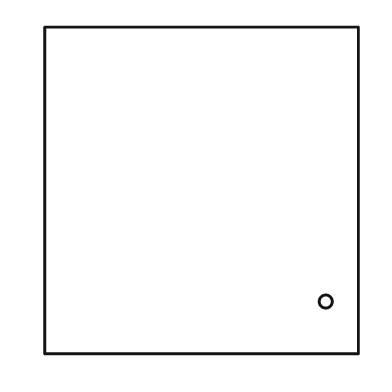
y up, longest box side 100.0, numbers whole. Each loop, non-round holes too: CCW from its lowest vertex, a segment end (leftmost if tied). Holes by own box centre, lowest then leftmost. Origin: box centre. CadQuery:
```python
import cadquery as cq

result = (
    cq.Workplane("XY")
    .moveTo(-48.0, -50.0)
    .lineTo(48.0, -50.0)
    .lineTo(48.0, 50.0)
    .lineTo(-48.0, 50.0)
    .close()
    .moveTo(38.0, -34.0)
    .circle(2.0)
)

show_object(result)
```